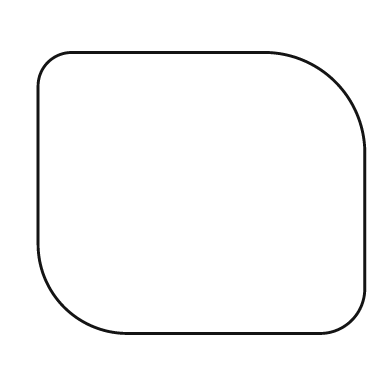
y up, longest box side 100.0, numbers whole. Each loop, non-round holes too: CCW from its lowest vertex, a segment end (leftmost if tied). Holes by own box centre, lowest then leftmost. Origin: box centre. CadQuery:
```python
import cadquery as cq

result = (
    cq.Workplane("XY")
    .moveTo(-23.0, -43.0)
    .lineTo(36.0, -43.0)
    .threePointArc((46.0, -39.0), (50.0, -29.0))
    .lineTo(50.0, 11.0)
    .threePointArc((41.0, 34.0), (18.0, 43.0))
    .lineTo(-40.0, 43.0)
    .threePointArc((-47.0, 40.0), (-50.0, 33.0))
    .lineTo(-50.0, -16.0)
    .threePointArc((-42.0, -35.0), (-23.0, -43.0))
    .close()
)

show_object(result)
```